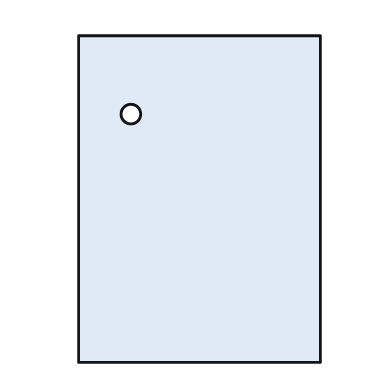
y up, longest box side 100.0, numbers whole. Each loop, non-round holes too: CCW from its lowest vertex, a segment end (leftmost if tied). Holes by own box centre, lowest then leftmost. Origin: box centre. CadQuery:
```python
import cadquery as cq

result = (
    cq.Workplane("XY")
    .moveTo(-37.0, -50.0)
    .lineTo(37.0, -50.0)
    .lineTo(37.0, 50.0)
    .lineTo(-37.0, 50.0)
    .close()
    .moveTo(-21.0, 26.0)
    .circle(3.0)
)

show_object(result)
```